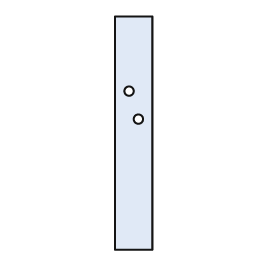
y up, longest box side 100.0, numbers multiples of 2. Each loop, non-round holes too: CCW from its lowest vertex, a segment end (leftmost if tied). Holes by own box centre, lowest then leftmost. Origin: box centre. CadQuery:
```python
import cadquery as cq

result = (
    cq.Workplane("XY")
    .moveTo(-8.0, -50.0)
    .lineTo(8.0, -50.0)
    .lineTo(8.0, 50.0)
    .lineTo(-8.0, 50.0)
    .close()
    .moveTo(2.0, 6.0)
    .circle(2.0)
    .moveTo(-2.0, 18.0)
    .circle(2.0)
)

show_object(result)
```